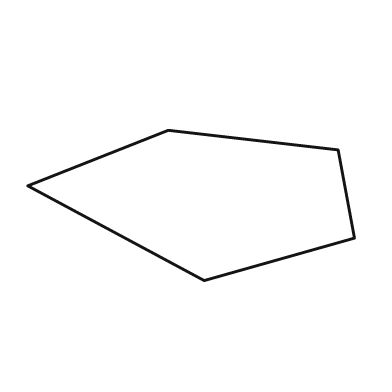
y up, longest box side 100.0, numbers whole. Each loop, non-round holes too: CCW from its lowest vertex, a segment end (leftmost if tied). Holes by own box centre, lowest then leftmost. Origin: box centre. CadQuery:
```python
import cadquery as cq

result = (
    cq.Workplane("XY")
    .moveTo(4.0, -23.0)
    .lineTo(50.0, -10.0)
    .lineTo(45.0, 17.0)
    .lineTo(-7.0, 23.0)
    .lineTo(-50.0, 6.0)
    .close()
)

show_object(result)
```